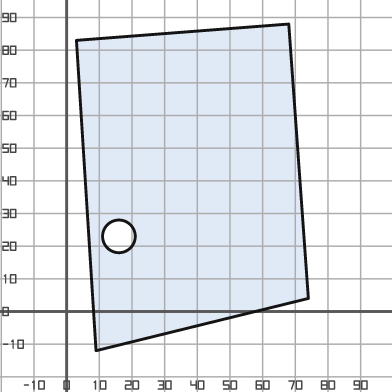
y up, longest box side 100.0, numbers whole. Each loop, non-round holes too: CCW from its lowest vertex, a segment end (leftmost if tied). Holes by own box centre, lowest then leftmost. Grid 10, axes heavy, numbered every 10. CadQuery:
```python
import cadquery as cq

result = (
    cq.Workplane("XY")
    .moveTo(9.0, -12.0)
    .lineTo(74.0, 4.0)
    .lineTo(68.0, 88.0)
    .lineTo(3.0, 83.0)
    .close()
    .moveTo(16.0, 23.0)
    .circle(5.0)
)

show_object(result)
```